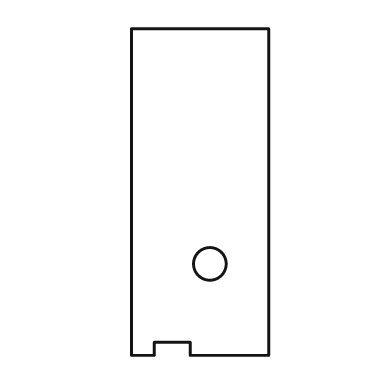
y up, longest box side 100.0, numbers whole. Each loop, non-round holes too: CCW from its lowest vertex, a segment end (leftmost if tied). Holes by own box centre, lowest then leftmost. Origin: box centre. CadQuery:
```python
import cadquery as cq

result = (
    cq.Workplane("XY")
    .moveTo(-21.0, -50.0)
    .lineTo(-14.0, -50.0)
    .lineTo(-14.0, -46.0)
    .lineTo(-3.0, -46.0)
    .lineTo(-3.0, -50.0)
    .lineTo(21.0, -50.0)
    .lineTo(21.0, 50.0)
    .lineTo(-21.0, 50.0)
    .close()
    .moveTo(3.0, -22.0)
    .circle(5.0)
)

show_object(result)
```